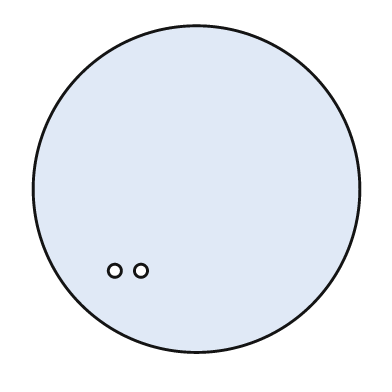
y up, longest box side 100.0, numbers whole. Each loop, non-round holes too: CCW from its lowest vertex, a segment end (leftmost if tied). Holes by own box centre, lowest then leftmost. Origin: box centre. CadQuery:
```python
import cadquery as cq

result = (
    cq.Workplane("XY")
    .moveTo(0.0, 0.0)
    .circle(50.0)
    .moveTo(-25.0, -25.0)
    .circle(2.0)
    .moveTo(-17.0, -25.0)
    .circle(2.0)
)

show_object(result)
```